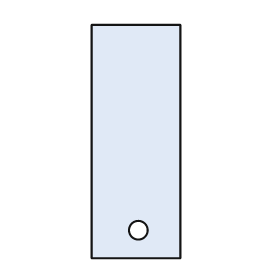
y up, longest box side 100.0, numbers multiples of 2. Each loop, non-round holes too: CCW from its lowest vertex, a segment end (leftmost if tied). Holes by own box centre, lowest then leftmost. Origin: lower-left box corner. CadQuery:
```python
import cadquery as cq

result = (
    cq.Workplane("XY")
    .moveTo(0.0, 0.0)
    .lineTo(38.0, 0.0)
    .lineTo(38.0, 100.0)
    .lineTo(0.0, 100.0)
    .close()
    .moveTo(20.0, 12.0)
    .circle(4.0)
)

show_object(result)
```